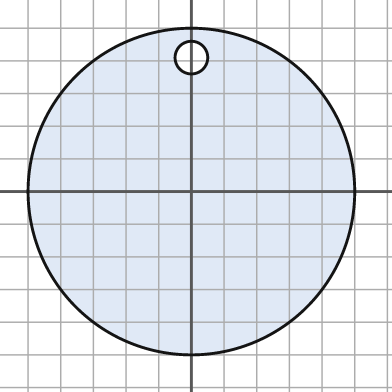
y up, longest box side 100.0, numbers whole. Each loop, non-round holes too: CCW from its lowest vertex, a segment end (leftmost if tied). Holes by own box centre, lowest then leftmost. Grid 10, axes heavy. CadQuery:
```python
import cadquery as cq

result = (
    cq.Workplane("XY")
    .moveTo(0.0, 0.0)
    .circle(50.0)
    .moveTo(0.0, 41.0)
    .circle(5.0)
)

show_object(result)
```